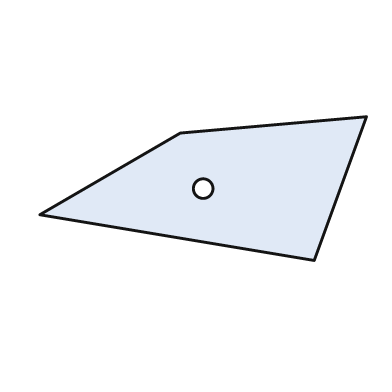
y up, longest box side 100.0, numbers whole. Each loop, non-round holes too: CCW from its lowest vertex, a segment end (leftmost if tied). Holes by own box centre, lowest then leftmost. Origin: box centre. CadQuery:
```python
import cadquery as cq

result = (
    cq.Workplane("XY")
    .moveTo(34.0, -22.0)
    .lineTo(50.0, 22.0)
    .lineTo(-7.0, 17.0)
    .lineTo(-50.0, -8.0)
    .close()
    .moveTo(0.0, 0.0)
    .circle(3.0)
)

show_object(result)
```